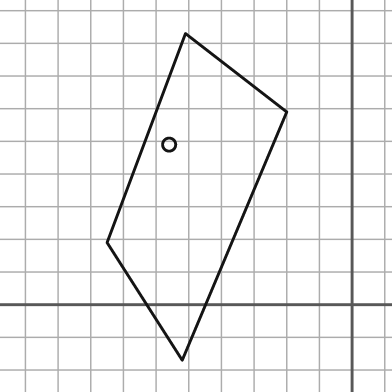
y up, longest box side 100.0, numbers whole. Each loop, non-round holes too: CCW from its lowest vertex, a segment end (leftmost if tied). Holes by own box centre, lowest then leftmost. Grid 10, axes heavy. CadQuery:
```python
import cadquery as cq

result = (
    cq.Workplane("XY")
    .moveTo(-52.0, -17.0)
    .lineTo(-20.0, 59.0)
    .lineTo(-51.0, 83.0)
    .lineTo(-75.0, 19.0)
    .close()
    .moveTo(-56.0, 49.0)
    .circle(2.0)
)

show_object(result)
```